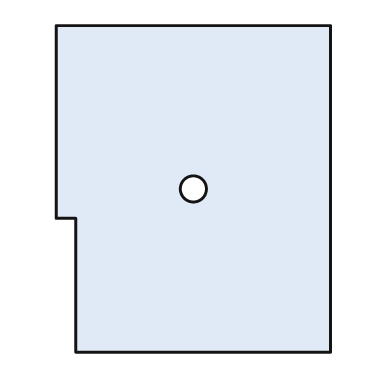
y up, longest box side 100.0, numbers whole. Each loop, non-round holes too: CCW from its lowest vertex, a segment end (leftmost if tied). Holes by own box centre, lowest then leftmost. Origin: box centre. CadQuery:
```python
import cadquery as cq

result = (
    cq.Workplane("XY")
    .moveTo(-36.0, -50.0)
    .lineTo(42.0, -50.0)
    .lineTo(42.0, 50.0)
    .lineTo(-42.0, 50.0)
    .lineTo(-42.0, -9.0)
    .lineTo(-36.0, -9.0)
    .close()
    .moveTo(0.0, 0.0)
    .circle(4.0)
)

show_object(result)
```